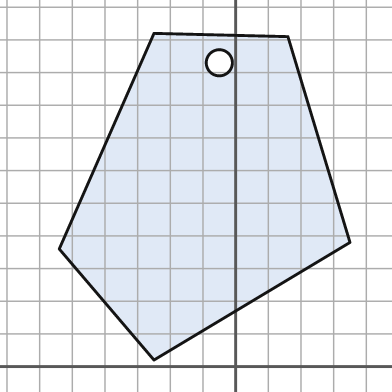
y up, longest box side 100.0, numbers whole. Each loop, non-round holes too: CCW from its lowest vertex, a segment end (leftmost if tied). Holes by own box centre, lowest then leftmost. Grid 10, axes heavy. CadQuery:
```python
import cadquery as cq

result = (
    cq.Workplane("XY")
    .moveTo(-25.0, 2.0)
    .lineTo(35.0, 38.0)
    .lineTo(16.0, 101.0)
    .lineTo(-25.0, 102.0)
    .lineTo(-54.0, 36.0)
    .close()
    .moveTo(-5.0, 93.0)
    .circle(4.0)
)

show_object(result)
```